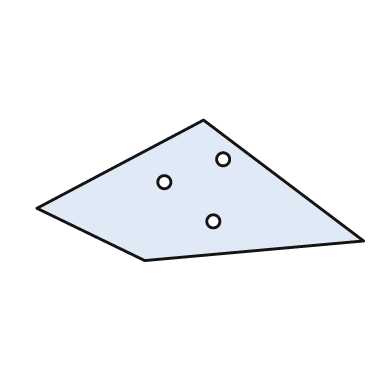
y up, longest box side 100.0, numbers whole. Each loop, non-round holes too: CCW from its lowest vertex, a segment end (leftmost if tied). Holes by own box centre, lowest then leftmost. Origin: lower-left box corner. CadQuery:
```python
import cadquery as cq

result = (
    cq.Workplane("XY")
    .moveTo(33.0, 0.0)
    .lineTo(100.0, 6.0)
    .lineTo(51.0, 43.0)
    .lineTo(0.0, 16.0)
    .close()
    .moveTo(54.0, 12.0)
    .circle(2.0)
    .moveTo(39.0, 24.0)
    .circle(2.0)
    .moveTo(57.0, 31.0)
    .circle(2.0)
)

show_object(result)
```